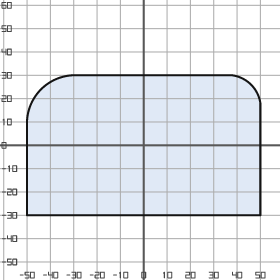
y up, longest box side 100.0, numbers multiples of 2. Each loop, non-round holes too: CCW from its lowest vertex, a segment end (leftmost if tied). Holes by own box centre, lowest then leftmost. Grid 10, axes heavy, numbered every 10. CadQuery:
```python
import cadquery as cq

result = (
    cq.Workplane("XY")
    .moveTo(-50.0, -30.0)
    .lineTo(50.0, -30.0)
    .lineTo(50.0, 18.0)
    .threePointArc((46.0, 26.0), (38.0, 30.0))
    .lineTo(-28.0, 30.0)
    .threePointArc((-44.0, 24.0), (-50.0, 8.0))
    .close()
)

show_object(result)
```